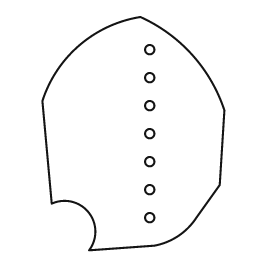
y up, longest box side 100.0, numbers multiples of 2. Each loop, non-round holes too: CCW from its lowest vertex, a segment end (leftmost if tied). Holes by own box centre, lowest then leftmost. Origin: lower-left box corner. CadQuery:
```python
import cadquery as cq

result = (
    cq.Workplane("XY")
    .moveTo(20.0, 0.0)
    .lineTo(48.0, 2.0)
    .threePointArc((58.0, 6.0), (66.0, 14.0))
    .lineTo(76.0, 28.0)
    .lineTo(78.0, 60.0)
    .threePointArc((64.0, 84.0), (42.0, 100.0))
    .threePointArc((16.0, 88.0), (0.0, 64.0))
    .lineTo(4.0, 20.0)
    .threePointArc((20.0, 16.0), (20.0, 0.0))
    .close()
    .moveTo(46.0, 14.0)
    .circle(2.0)
    .moveTo(46.0, 26.0)
    .circle(2.0)
    .moveTo(46.0, 38.0)
    .circle(2.0)
    .moveTo(46.0, 50.0)
    .circle(2.0)
    .moveTo(46.0, 62.0)
    .circle(2.0)
    .moveTo(46.0, 74.0)
    .circle(2.0)
    .moveTo(46.0, 86.0)
    .circle(2.0)
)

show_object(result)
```